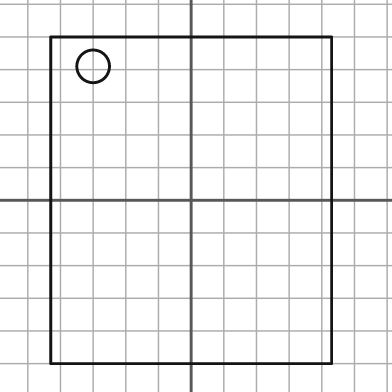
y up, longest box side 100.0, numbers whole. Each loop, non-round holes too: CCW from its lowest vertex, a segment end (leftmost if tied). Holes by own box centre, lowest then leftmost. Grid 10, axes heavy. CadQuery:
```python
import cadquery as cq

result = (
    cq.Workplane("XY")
    .moveTo(-43.0, -50.0)
    .lineTo(43.0, -50.0)
    .lineTo(43.0, 50.0)
    .lineTo(-43.0, 50.0)
    .close()
    .moveTo(-30.0, 41.0)
    .circle(5.0)
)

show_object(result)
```